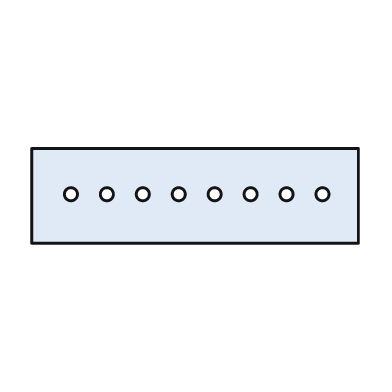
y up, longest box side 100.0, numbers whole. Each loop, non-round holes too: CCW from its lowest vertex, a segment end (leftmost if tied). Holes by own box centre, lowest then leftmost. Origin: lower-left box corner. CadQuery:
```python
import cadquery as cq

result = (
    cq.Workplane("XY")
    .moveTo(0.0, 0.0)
    .lineTo(100.0, 0.0)
    .lineTo(100.0, 29.0)
    .lineTo(0.0, 29.0)
    .close()
    .moveTo(12.0, 15.0)
    .circle(2.0)
    .moveTo(23.0, 15.0)
    .circle(2.0)
    .moveTo(34.0, 15.0)
    .circle(2.0)
    .moveTo(45.0, 15.0)
    .circle(2.0)
    .moveTo(56.0, 15.0)
    .circle(2.0)
    .moveTo(67.0, 15.0)
    .circle(2.0)
    .moveTo(78.0, 15.0)
    .circle(2.0)
    .moveTo(89.0, 15.0)
    .circle(2.0)
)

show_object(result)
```